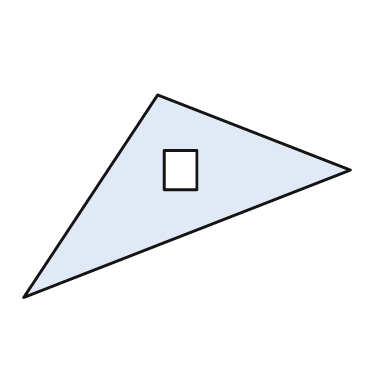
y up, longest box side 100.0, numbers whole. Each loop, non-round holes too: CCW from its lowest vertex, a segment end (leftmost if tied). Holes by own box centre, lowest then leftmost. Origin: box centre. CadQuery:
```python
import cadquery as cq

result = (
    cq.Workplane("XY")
    .moveTo(-50.0, -31.0)
    .lineTo(50.0, 8.0)
    .lineTo(-9.0, 31.0)
    .close()
    .moveTo(-7.0, 2.0)
    .lineTo(3.0, 2.0)
    .lineTo(3.0, 14.0)
    .lineTo(-7.0, 14.0)
    .close()
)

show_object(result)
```